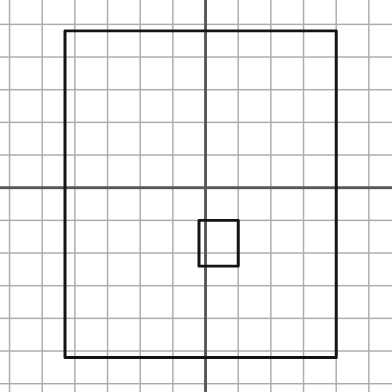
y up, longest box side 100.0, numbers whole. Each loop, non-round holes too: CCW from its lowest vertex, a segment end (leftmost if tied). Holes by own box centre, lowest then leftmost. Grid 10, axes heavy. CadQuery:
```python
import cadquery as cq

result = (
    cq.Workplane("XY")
    .moveTo(-43.0, -52.0)
    .lineTo(40.0, -52.0)
    .lineTo(40.0, 48.0)
    .lineTo(-43.0, 48.0)
    .close()
    .moveTo(-2.0, -24.0)
    .lineTo(10.0, -24.0)
    .lineTo(10.0, -10.0)
    .lineTo(-2.0, -10.0)
    .close()
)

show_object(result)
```